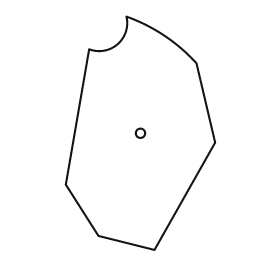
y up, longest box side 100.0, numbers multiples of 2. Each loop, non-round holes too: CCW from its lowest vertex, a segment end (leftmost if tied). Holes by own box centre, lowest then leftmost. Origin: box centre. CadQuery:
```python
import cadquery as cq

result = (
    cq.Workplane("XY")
    .moveTo(6.0, -50.0)
    .lineTo(32.0, -4.0)
    .lineTo(24.0, 30.0)
    .threePointArc((10.0, 42.0), (-6.0, 50.0))
    .threePointArc((-10.0, 38.0), (-22.0, 36.0))
    .lineTo(-32.0, -22.0)
    .lineTo(-18.0, -44.0)
    .close()
    .moveTo(0.0, 0.0)
    .circle(2.0)
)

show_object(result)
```